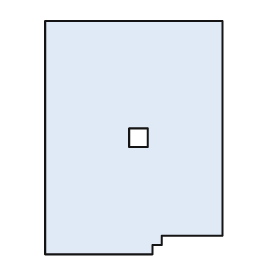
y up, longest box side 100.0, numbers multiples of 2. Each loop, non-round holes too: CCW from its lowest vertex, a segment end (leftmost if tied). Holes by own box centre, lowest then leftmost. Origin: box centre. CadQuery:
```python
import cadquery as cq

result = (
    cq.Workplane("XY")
    .moveTo(-38.0, -50.0)
    .lineTo(8.0, -50.0)
    .lineTo(8.0, -46.0)
    .lineTo(12.0, -46.0)
    .lineTo(12.0, -42.0)
    .lineTo(38.0, -42.0)
    .lineTo(38.0, 50.0)
    .lineTo(-38.0, 50.0)
    .close()
    .moveTo(-2.0, -4.0)
    .lineTo(6.0, -4.0)
    .lineTo(6.0, 4.0)
    .lineTo(-2.0, 4.0)
    .close()
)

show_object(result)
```